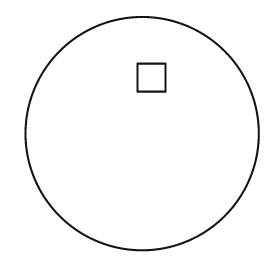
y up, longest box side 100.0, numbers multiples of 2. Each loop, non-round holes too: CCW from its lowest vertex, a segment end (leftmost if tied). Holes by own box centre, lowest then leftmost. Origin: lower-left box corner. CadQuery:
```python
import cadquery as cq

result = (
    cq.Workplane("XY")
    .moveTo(50.0, 50.0)
    .circle(50.0)
    .moveTo(48.0, 68.0)
    .lineTo(60.0, 68.0)
    .lineTo(60.0, 80.0)
    .lineTo(48.0, 80.0)
    .close()
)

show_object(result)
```